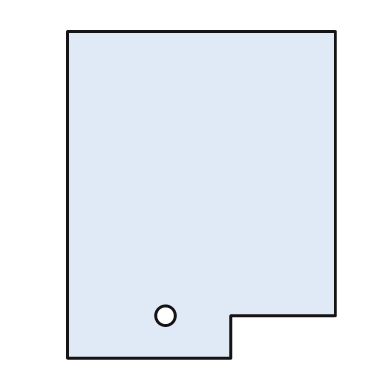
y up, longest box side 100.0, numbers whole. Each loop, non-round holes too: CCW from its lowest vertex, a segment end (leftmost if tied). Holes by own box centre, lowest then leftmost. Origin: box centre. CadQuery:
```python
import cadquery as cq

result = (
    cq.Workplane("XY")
    .moveTo(-41.0, -50.0)
    .lineTo(9.0, -50.0)
    .lineTo(9.0, -37.0)
    .lineTo(41.0, -37.0)
    .lineTo(41.0, 50.0)
    .lineTo(-41.0, 50.0)
    .close()
    .moveTo(-11.0, -37.0)
    .circle(3.0)
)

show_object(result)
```